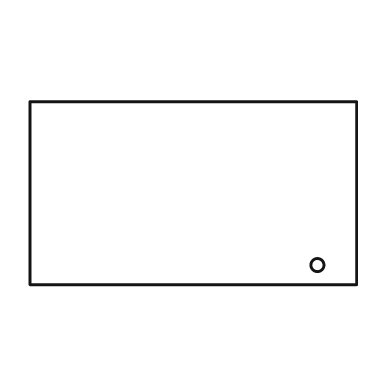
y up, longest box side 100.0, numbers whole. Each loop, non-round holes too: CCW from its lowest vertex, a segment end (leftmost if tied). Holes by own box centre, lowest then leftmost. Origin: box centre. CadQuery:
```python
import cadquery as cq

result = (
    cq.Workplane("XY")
    .moveTo(-50.0, -28.0)
    .lineTo(50.0, -28.0)
    .lineTo(50.0, 28.0)
    .lineTo(-50.0, 28.0)
    .close()
    .moveTo(38.0, -22.0)
    .circle(2.0)
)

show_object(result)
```